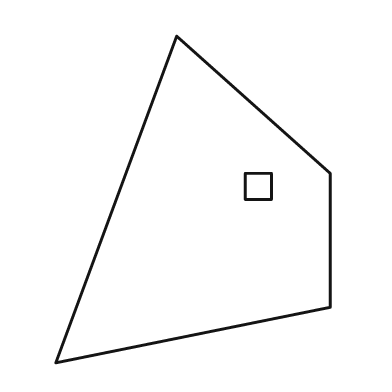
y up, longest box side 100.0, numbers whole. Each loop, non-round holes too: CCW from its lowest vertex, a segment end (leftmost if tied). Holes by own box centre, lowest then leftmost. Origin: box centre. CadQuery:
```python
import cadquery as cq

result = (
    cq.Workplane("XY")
    .moveTo(-42.0, -50.0)
    .lineTo(42.0, -33.0)
    .lineTo(42.0, 8.0)
    .lineTo(-5.0, 50.0)
    .close()
    .moveTo(16.0, 0.0)
    .lineTo(24.0, 0.0)
    .lineTo(24.0, 8.0)
    .lineTo(16.0, 8.0)
    .close()
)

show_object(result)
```